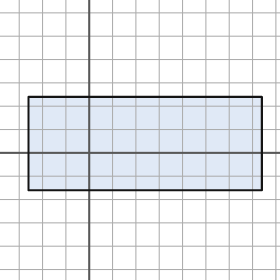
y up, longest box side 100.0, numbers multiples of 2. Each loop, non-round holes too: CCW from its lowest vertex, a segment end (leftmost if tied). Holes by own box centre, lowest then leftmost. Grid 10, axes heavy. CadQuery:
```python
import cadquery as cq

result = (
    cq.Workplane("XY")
    .moveTo(-26.0, -16.0)
    .lineTo(74.0, -16.0)
    .lineTo(74.0, 24.0)
    .lineTo(-26.0, 24.0)
    .close()
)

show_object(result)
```